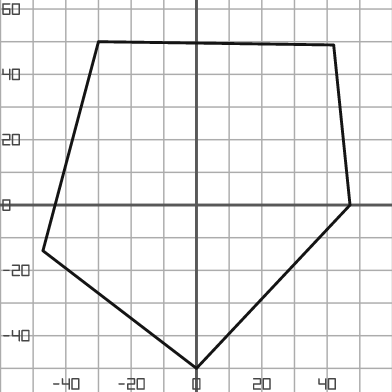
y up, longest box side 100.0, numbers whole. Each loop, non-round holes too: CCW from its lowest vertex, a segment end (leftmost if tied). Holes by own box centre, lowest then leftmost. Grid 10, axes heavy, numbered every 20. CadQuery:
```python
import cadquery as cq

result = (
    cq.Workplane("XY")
    .moveTo(0.0, -50.0)
    .lineTo(47.0, 0.0)
    .lineTo(42.0, 49.0)
    .lineTo(-30.0, 50.0)
    .lineTo(-47.0, -14.0)
    .close()
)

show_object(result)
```